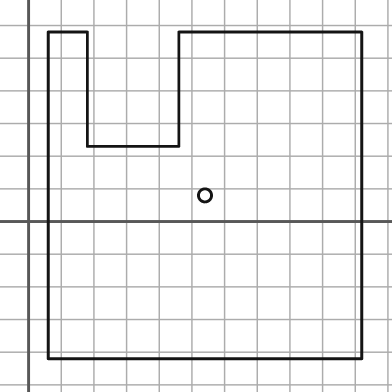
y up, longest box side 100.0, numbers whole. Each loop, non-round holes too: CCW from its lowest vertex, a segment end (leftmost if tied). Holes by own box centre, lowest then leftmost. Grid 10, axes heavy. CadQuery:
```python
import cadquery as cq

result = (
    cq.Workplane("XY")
    .moveTo(6.0, -42.0)
    .lineTo(102.0, -42.0)
    .lineTo(102.0, 58.0)
    .lineTo(46.0, 58.0)
    .lineTo(46.0, 23.0)
    .lineTo(18.0, 23.0)
    .lineTo(18.0, 58.0)
    .lineTo(6.0, 58.0)
    .close()
    .moveTo(54.0, 8.0)
    .circle(2.0)
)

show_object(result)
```